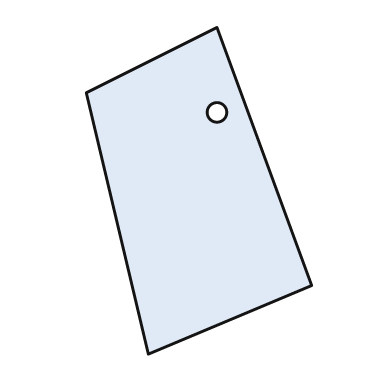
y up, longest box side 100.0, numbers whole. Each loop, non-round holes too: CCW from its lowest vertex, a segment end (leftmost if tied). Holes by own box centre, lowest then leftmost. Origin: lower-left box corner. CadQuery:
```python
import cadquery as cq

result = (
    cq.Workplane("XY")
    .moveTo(19.0, 0.0)
    .lineTo(69.0, 21.0)
    .lineTo(40.0, 100.0)
    .lineTo(0.0, 80.0)
    .close()
    .moveTo(40.0, 74.0)
    .circle(3.0)
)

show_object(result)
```